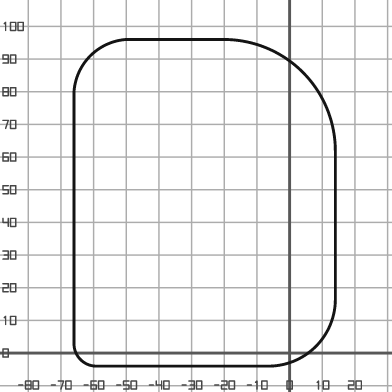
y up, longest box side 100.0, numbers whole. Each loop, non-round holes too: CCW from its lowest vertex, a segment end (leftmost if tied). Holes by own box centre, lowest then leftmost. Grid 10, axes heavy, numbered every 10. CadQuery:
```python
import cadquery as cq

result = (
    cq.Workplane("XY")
    .moveTo(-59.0, -4.0)
    .lineTo(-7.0, -4.0)
    .threePointArc((8.0, 2.0), (14.0, 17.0))
    .lineTo(14.0, 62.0)
    .threePointArc((4.0, 86.0), (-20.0, 96.0))
    .lineTo(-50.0, 96.0)
    .threePointArc((-61.0, 91.0), (-66.0, 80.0))
    .lineTo(-66.0, 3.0)
    .threePointArc((-64.0, -2.0), (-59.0, -4.0))
    .close()
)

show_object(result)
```